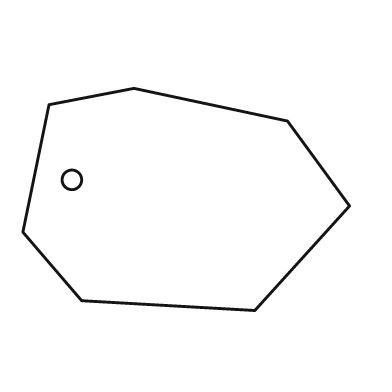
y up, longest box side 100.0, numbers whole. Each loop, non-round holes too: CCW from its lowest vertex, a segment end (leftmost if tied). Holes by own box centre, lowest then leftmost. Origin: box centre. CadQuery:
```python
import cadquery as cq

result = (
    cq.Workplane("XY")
    .moveTo(21.0, -34.0)
    .lineTo(50.0, -2.0)
    .lineTo(31.0, 24.0)
    .lineTo(-16.0, 34.0)
    .lineTo(-42.0, 29.0)
    .lineTo(-50.0, -10.0)
    .lineTo(-32.0, -31.0)
    .close()
    .moveTo(-35.0, 6.0)
    .circle(3.0)
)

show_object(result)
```